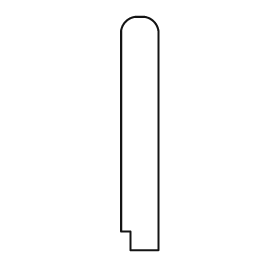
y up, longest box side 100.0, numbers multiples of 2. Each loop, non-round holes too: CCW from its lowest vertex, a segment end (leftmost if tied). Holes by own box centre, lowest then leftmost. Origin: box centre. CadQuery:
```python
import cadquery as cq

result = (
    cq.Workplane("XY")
    .moveTo(-4.0, -50.0)
    .lineTo(8.0, -50.0)
    .lineTo(8.0, 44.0)
    .threePointArc((6.0, 48.0), (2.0, 50.0))
    .lineTo(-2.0, 50.0)
    .threePointArc((-6.0, 48.0), (-8.0, 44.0))
    .lineTo(-8.0, -42.0)
    .lineTo(-4.0, -42.0)
    .close()
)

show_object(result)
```